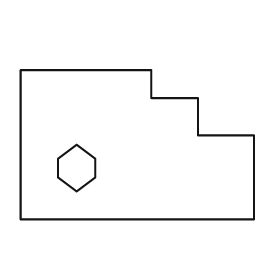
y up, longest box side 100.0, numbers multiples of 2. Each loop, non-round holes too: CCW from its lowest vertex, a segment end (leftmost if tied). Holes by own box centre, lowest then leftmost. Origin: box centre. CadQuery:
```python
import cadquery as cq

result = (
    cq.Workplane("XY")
    .moveTo(-50.0, -32.0)
    .lineTo(50.0, -32.0)
    .lineTo(50.0, 4.0)
    .lineTo(26.0, 4.0)
    .lineTo(26.0, 20.0)
    .lineTo(6.0, 20.0)
    .lineTo(6.0, 32.0)
    .lineTo(-50.0, 32.0)
    .close()
    .moveTo(-26.0, -20.0)
    .lineTo(-18.0, -14.0)
    .lineTo(-18.0, -6.0)
    .lineTo(-26.0, 0.0)
    .lineTo(-34.0, -6.0)
    .lineTo(-34.0, -14.0)
    .close()
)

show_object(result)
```